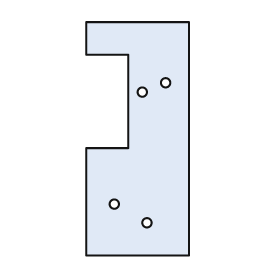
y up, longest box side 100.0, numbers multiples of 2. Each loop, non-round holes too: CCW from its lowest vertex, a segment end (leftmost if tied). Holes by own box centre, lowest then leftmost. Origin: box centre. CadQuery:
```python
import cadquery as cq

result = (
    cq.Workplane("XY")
    .moveTo(-22.0, -50.0)
    .lineTo(22.0, -50.0)
    .lineTo(22.0, 50.0)
    .lineTo(-22.0, 50.0)
    .lineTo(-22.0, 36.0)
    .lineTo(-4.0, 36.0)
    .lineTo(-4.0, -4.0)
    .lineTo(-22.0, -4.0)
    .close()
    .moveTo(4.0, -36.0)
    .circle(2.0)
    .moveTo(-10.0, -28.0)
    .circle(2.0)
    .moveTo(2.0, 20.0)
    .circle(2.0)
    .moveTo(12.0, 24.0)
    .circle(2.0)
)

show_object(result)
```